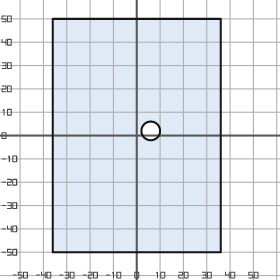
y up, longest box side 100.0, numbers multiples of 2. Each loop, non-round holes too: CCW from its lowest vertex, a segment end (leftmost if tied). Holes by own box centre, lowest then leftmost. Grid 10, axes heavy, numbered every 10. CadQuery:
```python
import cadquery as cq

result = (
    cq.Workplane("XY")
    .moveTo(-36.0, -50.0)
    .lineTo(36.0, -50.0)
    .lineTo(36.0, 50.0)
    .lineTo(-36.0, 50.0)
    .close()
    .moveTo(6.0, 2.0)
    .circle(4.0)
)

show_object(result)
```